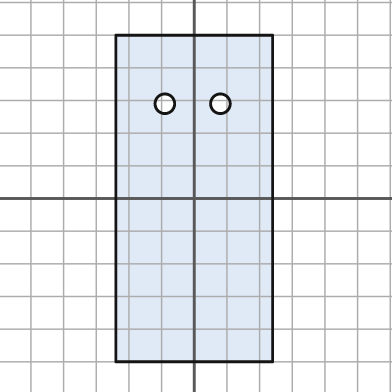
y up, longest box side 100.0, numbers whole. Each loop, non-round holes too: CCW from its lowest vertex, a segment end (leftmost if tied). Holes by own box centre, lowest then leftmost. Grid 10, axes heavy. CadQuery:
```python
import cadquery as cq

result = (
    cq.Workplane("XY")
    .moveTo(-24.0, -50.0)
    .lineTo(24.0, -50.0)
    .lineTo(24.0, 50.0)
    .lineTo(-24.0, 50.0)
    .close()
    .moveTo(-9.0, 29.0)
    .circle(3.0)
    .moveTo(8.0, 29.0)
    .circle(3.0)
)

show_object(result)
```